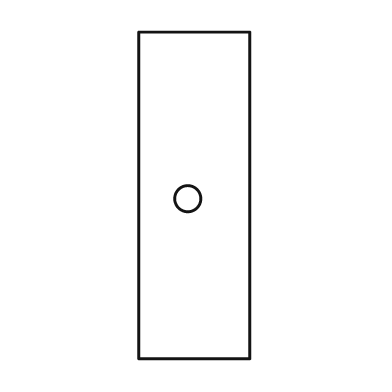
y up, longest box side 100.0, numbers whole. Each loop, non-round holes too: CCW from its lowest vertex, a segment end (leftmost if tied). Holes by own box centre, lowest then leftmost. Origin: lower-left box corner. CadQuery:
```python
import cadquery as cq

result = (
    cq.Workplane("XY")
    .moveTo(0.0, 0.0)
    .lineTo(34.0, 0.0)
    .lineTo(34.0, 100.0)
    .lineTo(0.0, 100.0)
    .close()
    .moveTo(15.0, 49.0)
    .circle(4.0)
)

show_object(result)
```